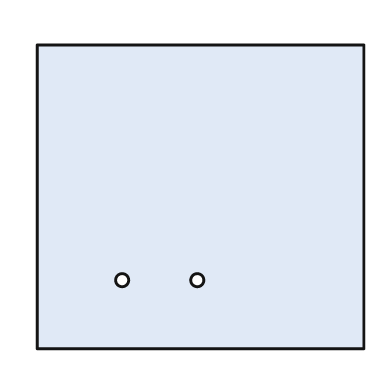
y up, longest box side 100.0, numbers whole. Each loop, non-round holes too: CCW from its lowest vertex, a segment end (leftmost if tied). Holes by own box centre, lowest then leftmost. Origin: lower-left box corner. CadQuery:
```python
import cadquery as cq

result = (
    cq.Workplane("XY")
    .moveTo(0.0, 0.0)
    .lineTo(100.0, 0.0)
    .lineTo(100.0, 93.0)
    .lineTo(0.0, 93.0)
    .close()
    .moveTo(26.0, 21.0)
    .circle(2.0)
    .moveTo(49.0, 21.0)
    .circle(2.0)
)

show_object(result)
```